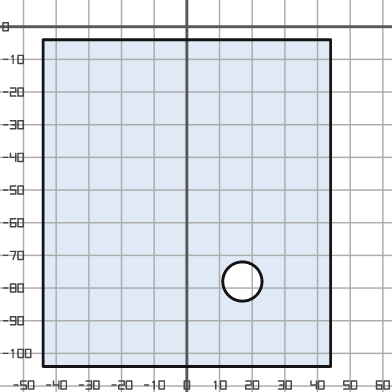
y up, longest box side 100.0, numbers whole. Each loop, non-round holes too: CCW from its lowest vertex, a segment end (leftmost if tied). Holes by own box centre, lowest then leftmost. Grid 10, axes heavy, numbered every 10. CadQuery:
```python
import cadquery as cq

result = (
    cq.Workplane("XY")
    .moveTo(-44.0, -104.0)
    .lineTo(44.0, -104.0)
    .lineTo(44.0, -4.0)
    .lineTo(-44.0, -4.0)
    .close()
    .moveTo(17.0, -78.0)
    .circle(6.0)
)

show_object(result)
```